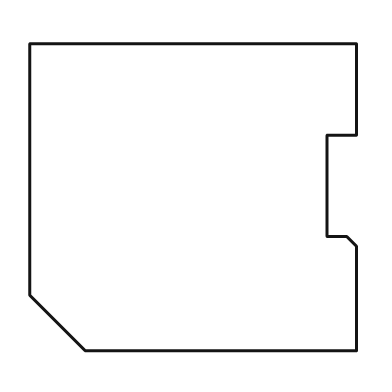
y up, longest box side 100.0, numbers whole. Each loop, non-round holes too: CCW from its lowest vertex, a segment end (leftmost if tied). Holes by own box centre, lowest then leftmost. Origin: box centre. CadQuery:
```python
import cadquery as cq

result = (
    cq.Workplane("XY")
    .moveTo(-33.0, -47.0)
    .lineTo(50.0, -47.0)
    .lineTo(50.0, -15.0)
    .lineTo(47.0, -12.0)
    .lineTo(41.0, -12.0)
    .lineTo(41.0, 19.0)
    .lineTo(50.0, 19.0)
    .lineTo(50.0, 47.0)
    .lineTo(-50.0, 47.0)
    .lineTo(-50.0, -30.0)
    .close()
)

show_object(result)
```